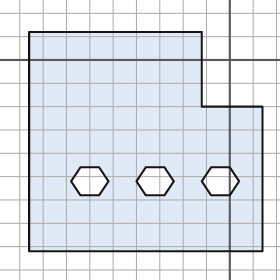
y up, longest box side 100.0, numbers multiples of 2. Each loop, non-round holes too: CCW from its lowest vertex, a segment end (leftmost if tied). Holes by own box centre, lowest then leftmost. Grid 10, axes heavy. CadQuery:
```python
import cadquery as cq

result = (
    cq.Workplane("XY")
    .moveTo(-86.0, -82.0)
    .lineTo(14.0, -82.0)
    .lineTo(14.0, -20.0)
    .lineTo(-12.0, -20.0)
    .lineTo(-12.0, 12.0)
    .lineTo(-86.0, 12.0)
    .close()
    .moveTo(-64.0, -58.0)
    .lineTo(-56.0, -58.0)
    .lineTo(-52.0, -52.0)
    .lineTo(-56.0, -46.0)
    .lineTo(-64.0, -46.0)
    .lineTo(-68.0, -52.0)
    .close()
    .moveTo(-36.0, -58.0)
    .lineTo(-28.0, -58.0)
    .lineTo(-24.0, -52.0)
    .lineTo(-28.0, -46.0)
    .lineTo(-36.0, -46.0)
    .lineTo(-40.0, -52.0)
    .close()
    .moveTo(-8.0, -58.0)
    .lineTo(0.0, -58.0)
    .lineTo(4.0, -52.0)
    .lineTo(0.0, -46.0)
    .lineTo(-8.0, -46.0)
    .lineTo(-12.0, -52.0)
    .close()
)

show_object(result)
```